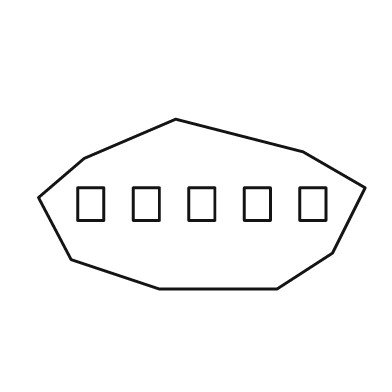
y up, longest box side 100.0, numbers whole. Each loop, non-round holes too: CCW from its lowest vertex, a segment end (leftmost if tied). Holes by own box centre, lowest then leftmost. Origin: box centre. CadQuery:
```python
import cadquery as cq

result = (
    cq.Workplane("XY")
    .moveTo(-13.0, -26.0)
    .lineTo(23.0, -26.0)
    .lineTo(40.0, -15.0)
    .lineTo(50.0, 5.0)
    .lineTo(31.0, 16.0)
    .lineTo(-8.0, 26.0)
    .lineTo(-36.0, 14.0)
    .lineTo(-50.0, 2.0)
    .lineTo(-40.0, -17.0)
    .close()
    .moveTo(-38.0, -5.0)
    .lineTo(-30.0, -5.0)
    .lineTo(-30.0, 5.0)
    .lineTo(-38.0, 5.0)
    .close()
    .moveTo(-21.0, -5.0)
    .lineTo(-13.0, -5.0)
    .lineTo(-13.0, 5.0)
    .lineTo(-21.0, 5.0)
    .close()
    .moveTo(-4.0, -5.0)
    .lineTo(4.0, -5.0)
    .lineTo(4.0, 5.0)
    .lineTo(-4.0, 5.0)
    .close()
    .moveTo(13.0, -5.0)
    .lineTo(21.0, -5.0)
    .lineTo(21.0, 5.0)
    .lineTo(13.0, 5.0)
    .close()
    .moveTo(30.0, -5.0)
    .lineTo(38.0, -5.0)
    .lineTo(38.0, 5.0)
    .lineTo(30.0, 5.0)
    .close()
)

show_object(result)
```